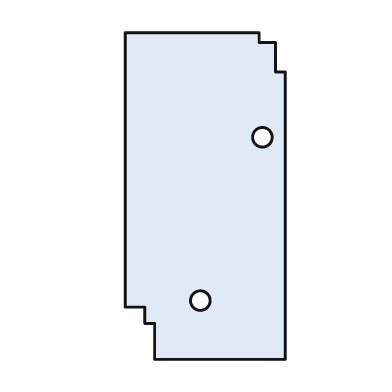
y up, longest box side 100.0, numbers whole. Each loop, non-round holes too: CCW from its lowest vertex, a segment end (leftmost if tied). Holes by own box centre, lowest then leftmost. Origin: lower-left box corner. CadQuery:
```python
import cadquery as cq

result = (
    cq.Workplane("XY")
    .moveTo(9.0, 0.0)
    .lineTo(49.0, 0.0)
    .lineTo(49.0, 88.0)
    .lineTo(46.0, 88.0)
    .lineTo(46.0, 97.0)
    .lineTo(41.0, 97.0)
    .lineTo(41.0, 100.0)
    .lineTo(0.0, 100.0)
    .lineTo(0.0, 16.0)
    .lineTo(6.0, 16.0)
    .lineTo(6.0, 11.0)
    .lineTo(9.0, 11.0)
    .close()
    .moveTo(23.0, 18.0)
    .circle(3.0)
    .moveTo(42.0, 68.0)
    .circle(3.0)
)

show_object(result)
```